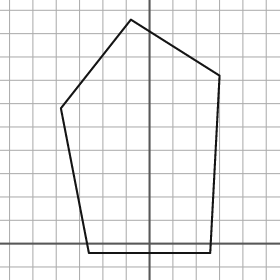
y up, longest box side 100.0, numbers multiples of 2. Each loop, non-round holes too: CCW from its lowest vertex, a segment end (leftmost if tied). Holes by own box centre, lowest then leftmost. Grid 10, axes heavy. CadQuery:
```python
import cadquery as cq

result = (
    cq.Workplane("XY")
    .moveTo(-26.0, -4.0)
    .lineTo(26.0, -4.0)
    .lineTo(30.0, 72.0)
    .lineTo(-8.0, 96.0)
    .lineTo(-38.0, 58.0)
    .close()
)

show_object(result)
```